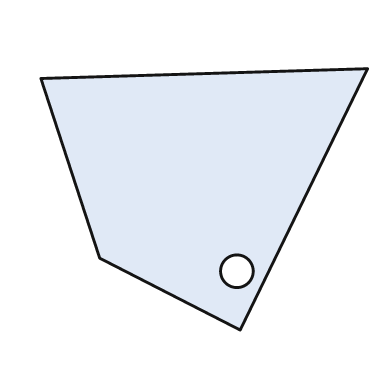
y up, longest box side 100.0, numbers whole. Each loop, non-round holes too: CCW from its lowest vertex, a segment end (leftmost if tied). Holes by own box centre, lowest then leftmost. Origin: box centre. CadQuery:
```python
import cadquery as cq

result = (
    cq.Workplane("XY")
    .moveTo(11.0, -40.0)
    .lineTo(50.0, 40.0)
    .lineTo(-50.0, 37.0)
    .lineTo(-32.0, -18.0)
    .close()
    .moveTo(10.0, -22.0)
    .circle(5.0)
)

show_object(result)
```